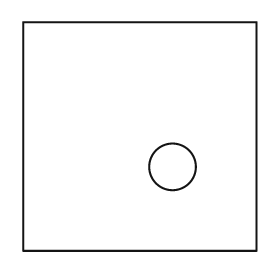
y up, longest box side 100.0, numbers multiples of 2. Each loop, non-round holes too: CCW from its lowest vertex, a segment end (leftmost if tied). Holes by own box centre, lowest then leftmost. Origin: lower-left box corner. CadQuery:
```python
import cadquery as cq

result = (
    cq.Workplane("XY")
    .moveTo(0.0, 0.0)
    .lineTo(100.0, 0.0)
    .lineTo(100.0, 98.0)
    .lineTo(0.0, 98.0)
    .close()
    .moveTo(64.0, 36.0)
    .circle(10.0)
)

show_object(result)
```